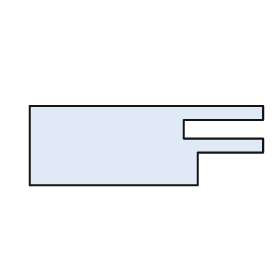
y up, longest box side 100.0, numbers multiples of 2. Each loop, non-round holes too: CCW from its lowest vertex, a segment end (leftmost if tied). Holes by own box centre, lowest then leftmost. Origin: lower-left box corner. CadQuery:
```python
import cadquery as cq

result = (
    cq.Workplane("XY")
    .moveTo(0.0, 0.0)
    .lineTo(72.0, 0.0)
    .lineTo(72.0, 14.0)
    .lineTo(100.0, 14.0)
    .lineTo(100.0, 20.0)
    .lineTo(66.0, 20.0)
    .lineTo(66.0, 28.0)
    .lineTo(100.0, 28.0)
    .lineTo(100.0, 34.0)
    .lineTo(0.0, 34.0)
    .close()
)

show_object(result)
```